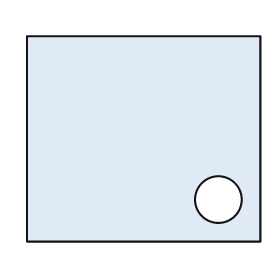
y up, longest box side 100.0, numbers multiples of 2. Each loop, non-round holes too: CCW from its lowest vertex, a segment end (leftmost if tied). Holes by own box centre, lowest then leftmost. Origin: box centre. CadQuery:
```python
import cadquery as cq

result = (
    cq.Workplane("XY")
    .moveTo(-50.0, -44.0)
    .lineTo(50.0, -44.0)
    .lineTo(50.0, 44.0)
    .lineTo(-50.0, 44.0)
    .close()
    .moveTo(32.0, -26.0)
    .circle(10.0)
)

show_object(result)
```